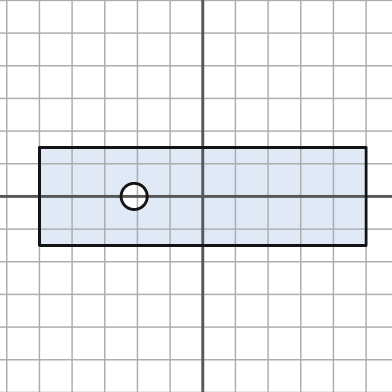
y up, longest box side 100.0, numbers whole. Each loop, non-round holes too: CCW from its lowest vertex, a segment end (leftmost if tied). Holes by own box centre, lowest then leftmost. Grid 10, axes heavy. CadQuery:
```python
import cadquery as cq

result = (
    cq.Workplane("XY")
    .moveTo(-50.0, -15.0)
    .lineTo(50.0, -15.0)
    .lineTo(50.0, 15.0)
    .lineTo(-50.0, 15.0)
    .close()
    .moveTo(-21.0, 0.0)
    .circle(4.0)
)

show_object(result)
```